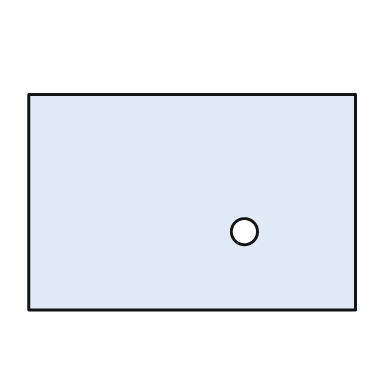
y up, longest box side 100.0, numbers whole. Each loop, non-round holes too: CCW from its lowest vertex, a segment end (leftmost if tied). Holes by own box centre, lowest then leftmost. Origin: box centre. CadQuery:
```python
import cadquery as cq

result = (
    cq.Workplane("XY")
    .moveTo(-50.0, -33.0)
    .lineTo(50.0, -33.0)
    .lineTo(50.0, 33.0)
    .lineTo(-50.0, 33.0)
    .close()
    .moveTo(16.0, -9.0)
    .circle(4.0)
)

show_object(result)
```